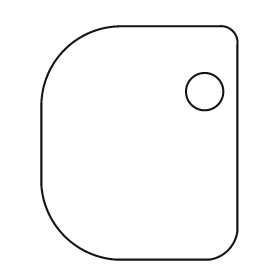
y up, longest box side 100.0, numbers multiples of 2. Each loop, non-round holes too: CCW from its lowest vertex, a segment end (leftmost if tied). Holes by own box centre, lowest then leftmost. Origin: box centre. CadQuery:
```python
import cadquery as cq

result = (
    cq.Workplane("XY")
    .moveTo(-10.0, -50.0)
    .lineTo(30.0, -50.0)
    .threePointArc((38.0, -46.0), (42.0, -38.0))
    .lineTo(42.0, 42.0)
    .threePointArc((40.0, 48.0), (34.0, 50.0))
    .lineTo(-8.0, 50.0)
    .threePointArc((-32.0, 40.0), (-42.0, 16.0))
    .lineTo(-42.0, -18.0)
    .threePointArc((-32.0, -40.0), (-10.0, -50.0))
    .close()
    .moveTo(28.0, 22.0)
    .circle(8.0)
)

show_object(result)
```